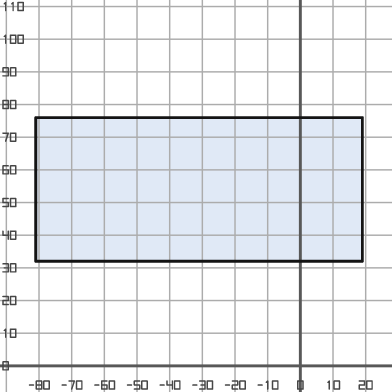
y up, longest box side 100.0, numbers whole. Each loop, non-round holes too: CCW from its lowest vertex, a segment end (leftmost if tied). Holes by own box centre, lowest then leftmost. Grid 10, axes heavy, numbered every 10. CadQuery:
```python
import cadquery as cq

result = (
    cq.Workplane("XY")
    .moveTo(-81.0, 32.0)
    .lineTo(19.0, 32.0)
    .lineTo(19.0, 76.0)
    .lineTo(-81.0, 76.0)
    .close()
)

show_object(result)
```